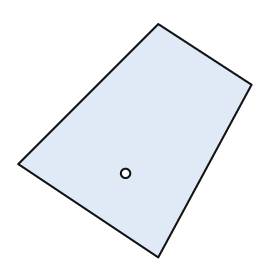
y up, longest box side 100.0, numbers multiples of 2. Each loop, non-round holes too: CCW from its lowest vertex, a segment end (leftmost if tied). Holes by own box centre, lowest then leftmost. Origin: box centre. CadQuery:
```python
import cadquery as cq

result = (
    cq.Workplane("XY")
    .moveTo(10.0, -50.0)
    .lineTo(50.0, 24.0)
    .lineTo(10.0, 50.0)
    .lineTo(-50.0, -10.0)
    .close()
    .moveTo(-4.0, -14.0)
    .circle(2.0)
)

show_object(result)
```